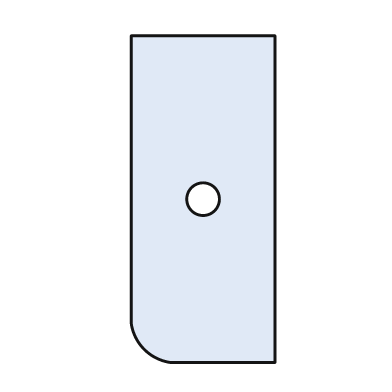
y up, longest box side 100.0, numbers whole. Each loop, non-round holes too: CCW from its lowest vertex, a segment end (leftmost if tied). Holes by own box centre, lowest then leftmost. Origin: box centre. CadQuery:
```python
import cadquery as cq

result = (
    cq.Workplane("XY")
    .moveTo(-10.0, -50.0)
    .lineTo(22.0, -50.0)
    .lineTo(22.0, 50.0)
    .lineTo(-22.0, 50.0)
    .lineTo(-22.0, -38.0)
    .threePointArc((-18.0, -46.0), (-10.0, -50.0))
    .close()
    .moveTo(0.0, 0.0)
    .circle(5.0)
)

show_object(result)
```